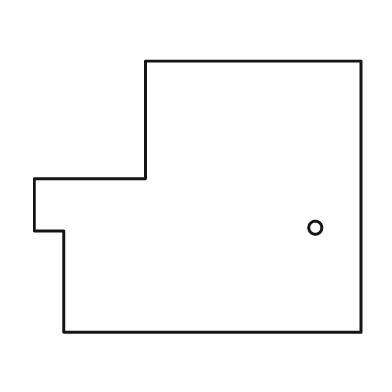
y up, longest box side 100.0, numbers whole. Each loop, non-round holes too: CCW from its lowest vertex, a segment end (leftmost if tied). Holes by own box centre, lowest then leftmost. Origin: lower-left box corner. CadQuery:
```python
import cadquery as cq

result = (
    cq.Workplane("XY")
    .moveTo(9.0, 0.0)
    .lineTo(100.0, 0.0)
    .lineTo(100.0, 83.0)
    .lineTo(34.0, 83.0)
    .lineTo(34.0, 47.0)
    .lineTo(0.0, 47.0)
    .lineTo(0.0, 31.0)
    .lineTo(9.0, 31.0)
    .close()
    .moveTo(86.0, 32.0)
    .circle(2.0)
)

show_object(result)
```